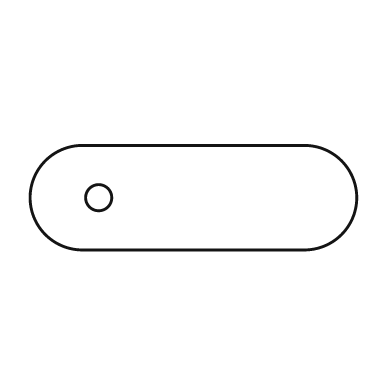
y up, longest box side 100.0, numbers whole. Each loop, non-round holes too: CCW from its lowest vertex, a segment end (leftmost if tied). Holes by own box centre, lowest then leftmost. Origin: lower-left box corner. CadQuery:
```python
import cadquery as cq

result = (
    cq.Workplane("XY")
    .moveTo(16.0, 0.0)
    .lineTo(84.0, 0.0)
    .threePointArc((100.0, 16.0), (84.0, 32.0))
    .lineTo(16.0, 32.0)
    .threePointArc((0.0, 16.0), (16.0, 0.0))
    .close()
    .moveTo(21.0, 16.0)
    .circle(4.0)
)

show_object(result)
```